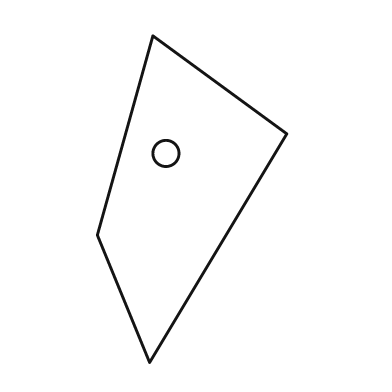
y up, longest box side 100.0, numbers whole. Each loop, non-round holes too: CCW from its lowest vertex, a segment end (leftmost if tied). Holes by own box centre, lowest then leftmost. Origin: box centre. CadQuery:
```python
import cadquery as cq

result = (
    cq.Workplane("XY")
    .moveTo(-13.0, -50.0)
    .lineTo(29.0, 20.0)
    .lineTo(-12.0, 50.0)
    .lineTo(-29.0, -11.0)
    .close()
    .moveTo(-8.0, 14.0)
    .circle(4.0)
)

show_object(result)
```